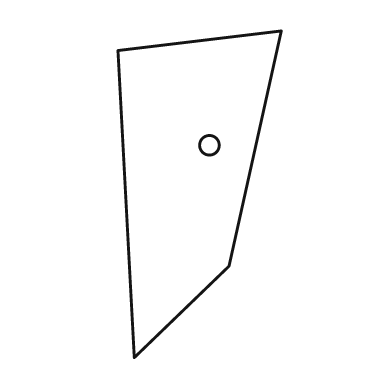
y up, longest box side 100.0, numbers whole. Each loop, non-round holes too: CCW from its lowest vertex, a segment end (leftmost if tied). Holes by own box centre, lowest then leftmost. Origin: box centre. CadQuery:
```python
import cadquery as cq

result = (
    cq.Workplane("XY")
    .moveTo(-20.0, -50.0)
    .lineTo(9.0, -22.0)
    .lineTo(25.0, 50.0)
    .lineTo(-25.0, 44.0)
    .close()
    .moveTo(3.0, 15.0)
    .circle(3.0)
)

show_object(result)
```